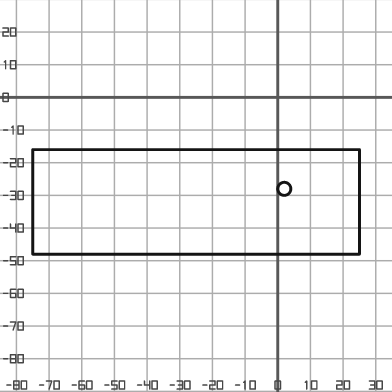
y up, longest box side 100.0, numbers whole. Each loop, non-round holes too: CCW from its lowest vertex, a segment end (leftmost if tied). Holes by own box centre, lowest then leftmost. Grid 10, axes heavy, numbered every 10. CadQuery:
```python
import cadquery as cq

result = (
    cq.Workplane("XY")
    .moveTo(-75.0, -48.0)
    .lineTo(25.0, -48.0)
    .lineTo(25.0, -16.0)
    .lineTo(-75.0, -16.0)
    .close()
    .moveTo(2.0, -28.0)
    .circle(2.0)
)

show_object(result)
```